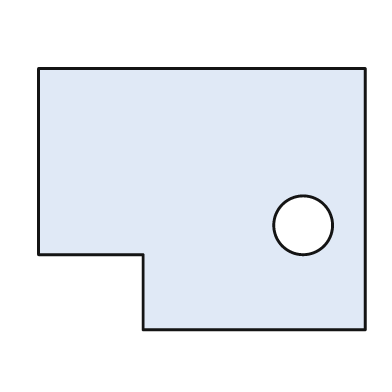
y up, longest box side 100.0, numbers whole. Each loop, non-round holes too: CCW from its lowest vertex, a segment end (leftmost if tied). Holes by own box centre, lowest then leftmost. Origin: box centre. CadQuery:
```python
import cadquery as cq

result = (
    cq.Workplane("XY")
    .moveTo(-18.0, -40.0)
    .lineTo(50.0, -40.0)
    .lineTo(50.0, 40.0)
    .lineTo(-50.0, 40.0)
    .lineTo(-50.0, -17.0)
    .lineTo(-18.0, -17.0)
    .close()
    .moveTo(31.0, -8.0)
    .circle(9.0)
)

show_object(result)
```